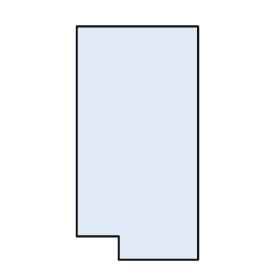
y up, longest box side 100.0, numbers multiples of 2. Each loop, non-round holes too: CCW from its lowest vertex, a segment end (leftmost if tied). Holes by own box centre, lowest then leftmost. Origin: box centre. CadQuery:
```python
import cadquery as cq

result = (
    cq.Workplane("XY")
    .moveTo(-8.0, -50.0)
    .lineTo(26.0, -50.0)
    .lineTo(26.0, 50.0)
    .lineTo(-26.0, 50.0)
    .lineTo(-26.0, -40.0)
    .lineTo(-8.0, -40.0)
    .close()
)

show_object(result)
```